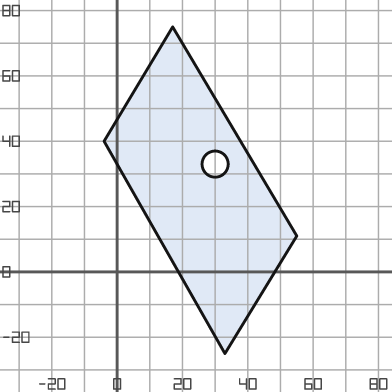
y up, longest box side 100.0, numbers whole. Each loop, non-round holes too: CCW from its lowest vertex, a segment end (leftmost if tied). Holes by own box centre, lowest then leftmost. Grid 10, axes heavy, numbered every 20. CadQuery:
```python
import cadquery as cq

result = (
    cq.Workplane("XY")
    .moveTo(33.0, -25.0)
    .lineTo(55.0, 11.0)
    .lineTo(17.0, 75.0)
    .lineTo(-4.0, 40.0)
    .close()
    .moveTo(30.0, 33.0)
    .circle(4.0)
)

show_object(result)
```